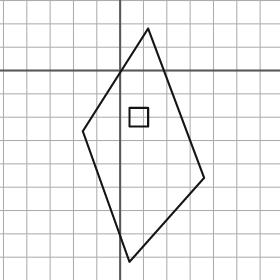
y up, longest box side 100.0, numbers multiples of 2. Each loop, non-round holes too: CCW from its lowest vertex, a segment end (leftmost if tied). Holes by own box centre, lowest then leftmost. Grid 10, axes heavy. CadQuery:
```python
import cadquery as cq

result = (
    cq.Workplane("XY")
    .moveTo(4.0, -82.0)
    .lineTo(36.0, -46.0)
    .lineTo(12.0, 18.0)
    .lineTo(-16.0, -26.0)
    .close()
    .moveTo(4.0, -24.0)
    .lineTo(12.0, -24.0)
    .lineTo(12.0, -16.0)
    .lineTo(4.0, -16.0)
    .close()
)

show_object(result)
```